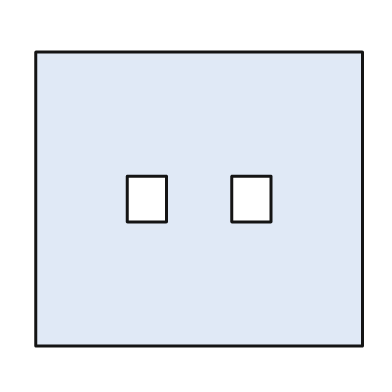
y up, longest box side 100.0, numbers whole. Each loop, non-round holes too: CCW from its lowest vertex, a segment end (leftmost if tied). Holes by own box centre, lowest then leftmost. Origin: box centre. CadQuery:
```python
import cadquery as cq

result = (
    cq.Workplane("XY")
    .moveTo(-50.0, -45.0)
    .lineTo(50.0, -45.0)
    .lineTo(50.0, 45.0)
    .lineTo(-50.0, 45.0)
    .close()
    .moveTo(-22.0, -7.0)
    .lineTo(-10.0, -7.0)
    .lineTo(-10.0, 7.0)
    .lineTo(-22.0, 7.0)
    .close()
    .moveTo(10.0, -7.0)
    .lineTo(22.0, -7.0)
    .lineTo(22.0, 7.0)
    .lineTo(10.0, 7.0)
    .close()
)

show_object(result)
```